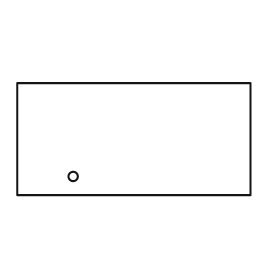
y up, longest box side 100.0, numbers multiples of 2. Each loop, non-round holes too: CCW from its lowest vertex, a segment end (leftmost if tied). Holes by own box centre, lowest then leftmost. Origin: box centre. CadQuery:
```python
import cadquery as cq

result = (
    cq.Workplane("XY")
    .moveTo(-50.0, -24.0)
    .lineTo(50.0, -24.0)
    .lineTo(50.0, 24.0)
    .lineTo(-50.0, 24.0)
    .close()
    .moveTo(-26.0, -16.0)
    .circle(2.0)
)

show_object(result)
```